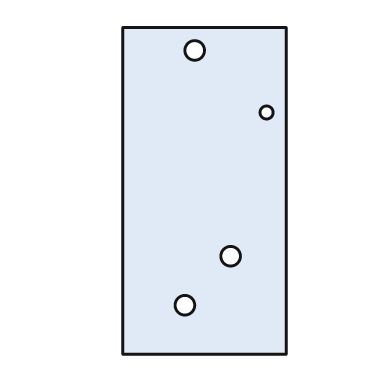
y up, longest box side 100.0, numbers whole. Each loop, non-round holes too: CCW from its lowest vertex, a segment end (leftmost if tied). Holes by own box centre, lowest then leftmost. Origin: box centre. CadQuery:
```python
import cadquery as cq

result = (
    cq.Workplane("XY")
    .moveTo(-25.0, -50.0)
    .lineTo(25.0, -50.0)
    .lineTo(25.0, 50.0)
    .lineTo(-25.0, 50.0)
    .close()
    .moveTo(-6.0, -35.0)
    .circle(3.0)
    .moveTo(8.0, -20.0)
    .circle(3.0)
    .moveTo(19.0, 24.0)
    .circle(2.0)
    .moveTo(-3.0, 43.0)
    .circle(3.0)
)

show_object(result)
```